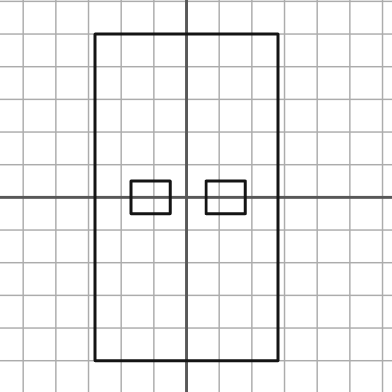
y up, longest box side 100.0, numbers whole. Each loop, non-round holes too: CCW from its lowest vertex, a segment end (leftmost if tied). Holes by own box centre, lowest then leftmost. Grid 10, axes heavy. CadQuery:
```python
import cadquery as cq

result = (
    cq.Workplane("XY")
    .moveTo(-28.0, -50.0)
    .lineTo(28.0, -50.0)
    .lineTo(28.0, 50.0)
    .lineTo(-28.0, 50.0)
    .close()
    .moveTo(-17.0, -5.0)
    .lineTo(-5.0, -5.0)
    .lineTo(-5.0, 5.0)
    .lineTo(-17.0, 5.0)
    .close()
    .moveTo(6.0, -5.0)
    .lineTo(18.0, -5.0)
    .lineTo(18.0, 5.0)
    .lineTo(6.0, 5.0)
    .close()
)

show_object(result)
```